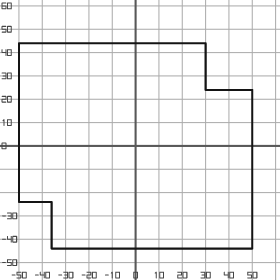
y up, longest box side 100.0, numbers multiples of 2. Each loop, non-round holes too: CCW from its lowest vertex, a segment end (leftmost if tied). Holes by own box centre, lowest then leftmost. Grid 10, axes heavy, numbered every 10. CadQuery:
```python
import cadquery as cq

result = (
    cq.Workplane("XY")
    .moveTo(-36.0, -44.0)
    .lineTo(50.0, -44.0)
    .lineTo(50.0, 24.0)
    .lineTo(30.0, 24.0)
    .lineTo(30.0, 44.0)
    .lineTo(-50.0, 44.0)
    .lineTo(-50.0, -24.0)
    .lineTo(-36.0, -24.0)
    .close()
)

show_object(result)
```